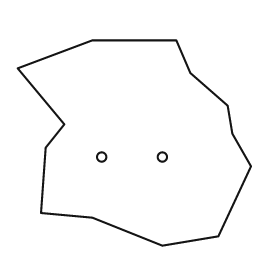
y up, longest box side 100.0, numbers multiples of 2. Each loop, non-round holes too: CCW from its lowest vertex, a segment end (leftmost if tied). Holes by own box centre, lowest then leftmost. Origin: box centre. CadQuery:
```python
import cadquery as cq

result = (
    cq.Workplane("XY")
    .moveTo(12.0, -44.0)
    .lineTo(36.0, -40.0)
    .lineTo(50.0, -10.0)
    .lineTo(42.0, 4.0)
    .lineTo(40.0, 16.0)
    .lineTo(24.0, 30.0)
    .lineTo(18.0, 44.0)
    .lineTo(-18.0, 44.0)
    .lineTo(-50.0, 32.0)
    .lineTo(-30.0, 8.0)
    .lineTo(-38.0, -2.0)
    .lineTo(-40.0, -30.0)
    .lineTo(-18.0, -32.0)
    .close()
    .moveTo(-14.0, -6.0)
    .circle(2.0)
    .moveTo(12.0, -6.0)
    .circle(2.0)
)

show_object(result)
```